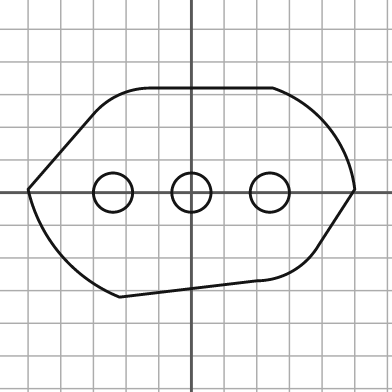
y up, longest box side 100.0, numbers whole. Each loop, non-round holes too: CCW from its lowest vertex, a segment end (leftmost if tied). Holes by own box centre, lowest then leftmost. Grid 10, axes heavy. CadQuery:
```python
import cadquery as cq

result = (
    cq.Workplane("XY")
    .moveTo(-22.0, -32.0)
    .lineTo(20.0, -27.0)
    .threePointArc((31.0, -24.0), (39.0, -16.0))
    .lineTo(50.0, 1.0)
    .threePointArc((42.0, 20.0), (25.0, 32.0))
    .lineTo(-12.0, 32.0)
    .threePointArc((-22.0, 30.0), (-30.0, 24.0))
    .lineTo(-50.0, 1.0)
    .threePointArc((-40.0, -19.0), (-22.0, -32.0))
    .close()
    .moveTo(-24.0, 0.0)
    .circle(6.0)
    .moveTo(0.0, 0.0)
    .circle(6.0)
    .moveTo(24.0, 0.0)
    .circle(6.0)
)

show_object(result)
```